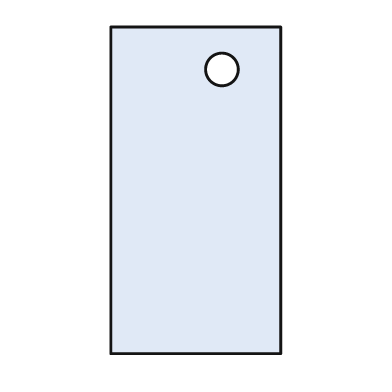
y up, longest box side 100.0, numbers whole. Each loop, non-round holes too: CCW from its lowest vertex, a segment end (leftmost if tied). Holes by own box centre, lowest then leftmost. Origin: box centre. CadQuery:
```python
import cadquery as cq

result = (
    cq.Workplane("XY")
    .moveTo(-26.0, -50.0)
    .lineTo(26.0, -50.0)
    .lineTo(26.0, 50.0)
    .lineTo(-26.0, 50.0)
    .close()
    .moveTo(8.0, 37.0)
    .circle(5.0)
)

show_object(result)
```